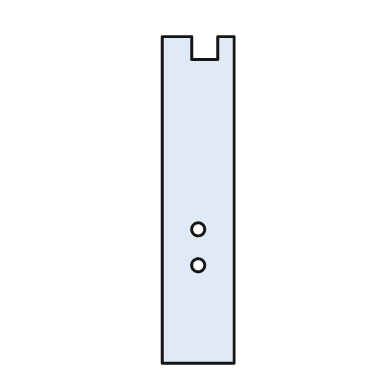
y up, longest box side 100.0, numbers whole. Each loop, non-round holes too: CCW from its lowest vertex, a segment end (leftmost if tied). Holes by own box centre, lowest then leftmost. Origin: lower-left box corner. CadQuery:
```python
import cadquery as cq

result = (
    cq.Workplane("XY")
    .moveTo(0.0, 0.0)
    .lineTo(22.0, 0.0)
    .lineTo(22.0, 100.0)
    .lineTo(17.0, 100.0)
    .lineTo(17.0, 93.0)
    .lineTo(9.0, 93.0)
    .lineTo(9.0, 100.0)
    .lineTo(0.0, 100.0)
    .close()
    .moveTo(11.0, 30.0)
    .circle(2.0)
    .moveTo(11.0, 41.0)
    .circle(2.0)
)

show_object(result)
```